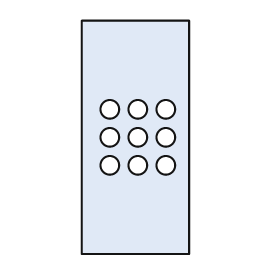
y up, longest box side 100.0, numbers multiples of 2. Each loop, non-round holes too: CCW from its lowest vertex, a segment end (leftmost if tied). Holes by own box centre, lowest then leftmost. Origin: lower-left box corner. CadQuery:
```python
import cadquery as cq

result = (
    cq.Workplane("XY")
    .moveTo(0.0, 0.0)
    .lineTo(46.0, 0.0)
    .lineTo(46.0, 100.0)
    .lineTo(0.0, 100.0)
    .close()
    .moveTo(12.0, 38.0)
    .circle(4.0)
    .moveTo(24.0, 38.0)
    .circle(4.0)
    .moveTo(36.0, 38.0)
    .circle(4.0)
    .moveTo(12.0, 50.0)
    .circle(4.0)
    .moveTo(24.0, 50.0)
    .circle(4.0)
    .moveTo(36.0, 50.0)
    .circle(4.0)
    .moveTo(12.0, 62.0)
    .circle(4.0)
    .moveTo(24.0, 62.0)
    .circle(4.0)
    .moveTo(36.0, 62.0)
    .circle(4.0)
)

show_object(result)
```